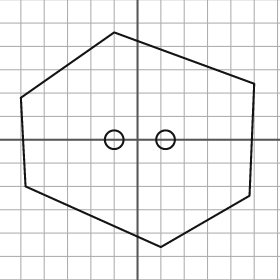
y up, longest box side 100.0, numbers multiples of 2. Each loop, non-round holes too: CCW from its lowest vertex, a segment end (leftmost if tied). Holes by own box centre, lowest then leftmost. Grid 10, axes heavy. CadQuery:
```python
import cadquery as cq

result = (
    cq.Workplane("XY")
    .moveTo(10.0, -46.0)
    .lineTo(48.0, -24.0)
    .lineTo(50.0, 24.0)
    .lineTo(-10.0, 46.0)
    .lineTo(-50.0, 18.0)
    .lineTo(-48.0, -20.0)
    .close()
    .moveTo(-10.0, 0.0)
    .circle(4.0)
    .moveTo(12.0, 0.0)
    .circle(4.0)
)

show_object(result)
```